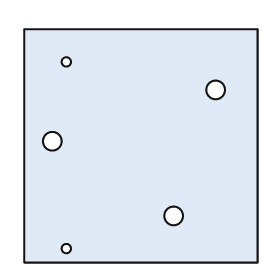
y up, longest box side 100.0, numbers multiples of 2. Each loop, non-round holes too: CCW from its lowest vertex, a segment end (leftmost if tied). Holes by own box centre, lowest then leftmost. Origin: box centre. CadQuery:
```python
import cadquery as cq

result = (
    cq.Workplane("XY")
    .moveTo(-50.0, -50.0)
    .lineTo(50.0, -50.0)
    .lineTo(50.0, 50.0)
    .lineTo(-50.0, 50.0)
    .close()
    .moveTo(-32.0, -44.0)
    .circle(2.0)
    .moveTo(14.0, -30.0)
    .circle(4.0)
    .moveTo(-38.0, 2.0)
    .circle(4.0)
    .moveTo(32.0, 24.0)
    .circle(4.0)
    .moveTo(-32.0, 36.0)
    .circle(2.0)
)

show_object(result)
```